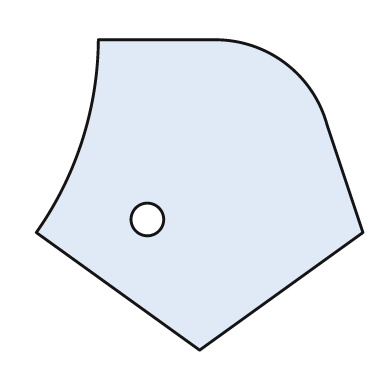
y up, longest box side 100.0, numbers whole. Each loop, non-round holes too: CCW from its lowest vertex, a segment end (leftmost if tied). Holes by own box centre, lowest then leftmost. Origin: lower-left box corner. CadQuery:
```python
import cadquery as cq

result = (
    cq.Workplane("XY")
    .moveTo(50.0, 0.0)
    .lineTo(100.0, 36.0)
    .lineTo(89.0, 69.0)
    .threePointArc((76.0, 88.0), (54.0, 95.0))
    .lineTo(19.0, 95.0)
    .threePointArc((14.0, 64.0), (0.0, 36.0))
    .close()
    .moveTo(34.0, 40.0)
    .circle(5.0)
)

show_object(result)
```